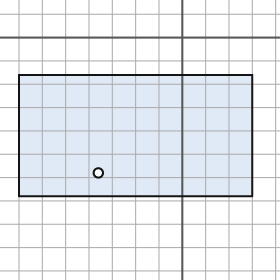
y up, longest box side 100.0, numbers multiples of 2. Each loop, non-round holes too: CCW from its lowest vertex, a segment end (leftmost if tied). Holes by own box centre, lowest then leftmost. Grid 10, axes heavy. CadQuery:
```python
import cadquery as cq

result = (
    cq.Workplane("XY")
    .moveTo(-70.0, -68.0)
    .lineTo(30.0, -68.0)
    .lineTo(30.0, -16.0)
    .lineTo(-70.0, -16.0)
    .close()
    .moveTo(-36.0, -58.0)
    .circle(2.0)
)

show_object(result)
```